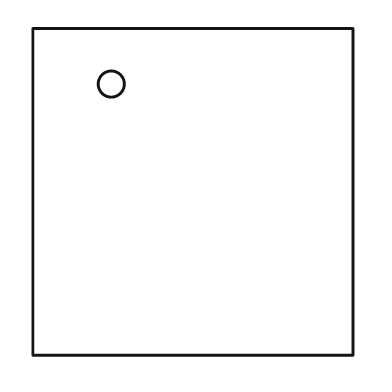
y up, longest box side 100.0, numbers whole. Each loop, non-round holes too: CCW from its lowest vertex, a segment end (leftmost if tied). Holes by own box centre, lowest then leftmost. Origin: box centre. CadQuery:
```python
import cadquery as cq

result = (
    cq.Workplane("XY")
    .moveTo(-49.0, -50.0)
    .lineTo(49.0, -50.0)
    .lineTo(49.0, 50.0)
    .lineTo(-49.0, 50.0)
    .close()
    .moveTo(-25.0, 33.0)
    .circle(4.0)
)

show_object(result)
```